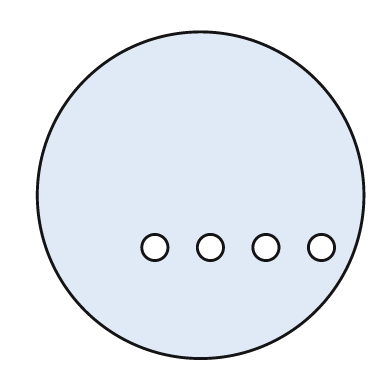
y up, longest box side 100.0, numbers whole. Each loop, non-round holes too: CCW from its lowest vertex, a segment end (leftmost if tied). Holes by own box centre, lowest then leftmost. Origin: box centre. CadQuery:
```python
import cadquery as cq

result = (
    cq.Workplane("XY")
    .moveTo(0.0, 0.0)
    .circle(50.0)
    .moveTo(-14.0, -16.0)
    .circle(4.0)
    .moveTo(3.0, -16.0)
    .circle(4.0)
    .moveTo(20.0, -16.0)
    .circle(4.0)
    .moveTo(37.0, -16.0)
    .circle(4.0)
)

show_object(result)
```